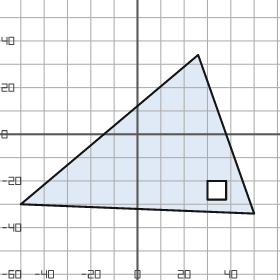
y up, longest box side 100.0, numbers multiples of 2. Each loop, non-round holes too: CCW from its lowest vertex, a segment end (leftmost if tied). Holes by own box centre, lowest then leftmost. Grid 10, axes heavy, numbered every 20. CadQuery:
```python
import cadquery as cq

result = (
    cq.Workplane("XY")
    .moveTo(50.0, -34.0)
    .lineTo(26.0, 34.0)
    .lineTo(-50.0, -30.0)
    .close()
    .moveTo(30.0, -28.0)
    .lineTo(38.0, -28.0)
    .lineTo(38.0, -20.0)
    .lineTo(30.0, -20.0)
    .close()
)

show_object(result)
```